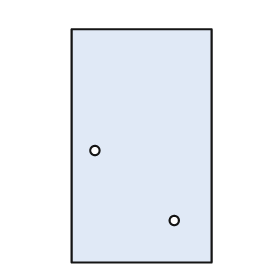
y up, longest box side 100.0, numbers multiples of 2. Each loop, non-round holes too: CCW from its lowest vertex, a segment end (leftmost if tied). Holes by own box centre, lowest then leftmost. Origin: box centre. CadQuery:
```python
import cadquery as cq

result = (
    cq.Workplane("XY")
    .moveTo(-30.0, -50.0)
    .lineTo(30.0, -50.0)
    .lineTo(30.0, 50.0)
    .lineTo(-30.0, 50.0)
    .close()
    .moveTo(14.0, -32.0)
    .circle(2.0)
    .moveTo(-20.0, -2.0)
    .circle(2.0)
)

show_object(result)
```